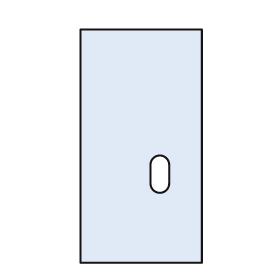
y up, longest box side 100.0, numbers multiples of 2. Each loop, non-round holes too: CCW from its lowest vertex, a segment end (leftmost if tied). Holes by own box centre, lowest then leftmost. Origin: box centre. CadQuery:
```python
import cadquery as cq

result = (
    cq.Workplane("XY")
    .moveTo(-26.0, -50.0)
    .lineTo(26.0, -50.0)
    .lineTo(26.0, 50.0)
    .lineTo(-26.0, 50.0)
    .close()
    .moveTo(4.0, -16.0)
    .threePointArc((8.0, -20.0), (12.0, -16.0))
    .lineTo(12.0, -8.0)
    .threePointArc((8.0, -4.0), (4.0, -8.0))
    .close()
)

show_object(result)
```